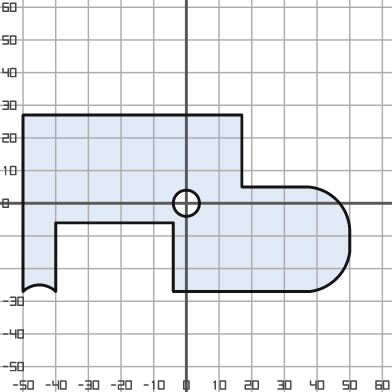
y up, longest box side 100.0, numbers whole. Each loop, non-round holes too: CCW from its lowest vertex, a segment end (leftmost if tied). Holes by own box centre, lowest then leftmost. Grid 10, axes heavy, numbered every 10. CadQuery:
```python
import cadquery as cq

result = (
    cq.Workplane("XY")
    .moveTo(-50.0, -27.0)
    .threePointArc((-45.0, -25.0), (-40.0, -27.0))
    .lineTo(-40.0, -6.0)
    .lineTo(-4.0, -6.0)
    .lineTo(-4.0, -27.0)
    .lineTo(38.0, -27.0)
    .threePointArc((46.0, -23.0), (50.0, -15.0))
    .lineTo(50.0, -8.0)
    .threePointArc((46.0, 1.0), (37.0, 5.0))
    .lineTo(17.0, 5.0)
    .lineTo(17.0, 27.0)
    .lineTo(-50.0, 27.0)
    .close()
    .moveTo(0.0, 0.0)
    .circle(4.0)
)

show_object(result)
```